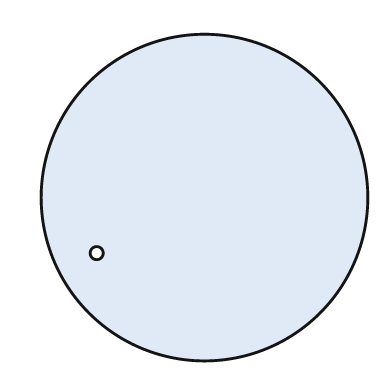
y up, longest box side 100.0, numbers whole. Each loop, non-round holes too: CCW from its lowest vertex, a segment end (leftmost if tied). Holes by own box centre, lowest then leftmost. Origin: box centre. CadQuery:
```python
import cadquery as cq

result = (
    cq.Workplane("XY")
    .moveTo(0.0, 0.0)
    .circle(50.0)
    .moveTo(-33.0, -17.0)
    .circle(2.0)
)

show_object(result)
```